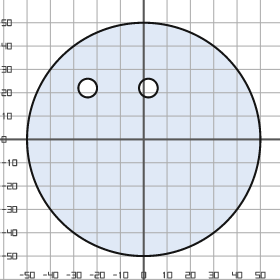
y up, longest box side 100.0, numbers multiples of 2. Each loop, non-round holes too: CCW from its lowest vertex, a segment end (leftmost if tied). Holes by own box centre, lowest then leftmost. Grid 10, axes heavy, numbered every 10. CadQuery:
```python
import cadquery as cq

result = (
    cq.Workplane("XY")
    .moveTo(0.0, 0.0)
    .circle(50.0)
    .moveTo(-24.0, 22.0)
    .circle(4.0)
    .moveTo(2.0, 22.0)
    .circle(4.0)
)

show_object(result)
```